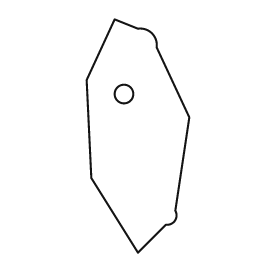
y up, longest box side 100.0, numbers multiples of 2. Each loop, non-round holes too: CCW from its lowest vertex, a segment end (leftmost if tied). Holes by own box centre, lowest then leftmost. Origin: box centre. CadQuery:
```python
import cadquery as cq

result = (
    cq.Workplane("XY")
    .moveTo(0.0, -50.0)
    .lineTo(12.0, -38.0)
    .threePointArc((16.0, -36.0), (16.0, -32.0))
    .lineTo(22.0, 8.0)
    .lineTo(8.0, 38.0)
    .threePointArc((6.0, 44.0), (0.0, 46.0))
    .lineTo(-10.0, 50.0)
    .lineTo(-22.0, 24.0)
    .lineTo(-20.0, -18.0)
    .close()
    .moveTo(-6.0, 18.0)
    .circle(4.0)
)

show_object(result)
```